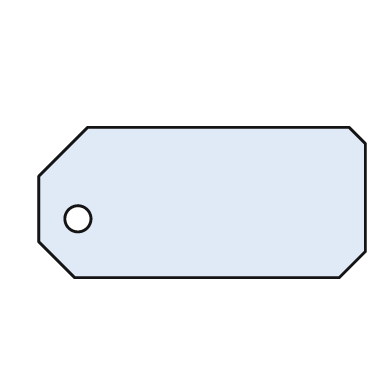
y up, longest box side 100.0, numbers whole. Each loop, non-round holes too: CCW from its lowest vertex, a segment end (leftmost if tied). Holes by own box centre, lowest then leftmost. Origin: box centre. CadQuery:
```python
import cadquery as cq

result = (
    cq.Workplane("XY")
    .moveTo(-39.0, -23.0)
    .lineTo(42.0, -23.0)
    .lineTo(50.0, -15.0)
    .lineTo(50.0, 18.0)
    .lineTo(45.0, 23.0)
    .lineTo(-35.0, 23.0)
    .lineTo(-50.0, 8.0)
    .lineTo(-50.0, -12.0)
    .close()
    .moveTo(-38.0, -5.0)
    .circle(4.0)
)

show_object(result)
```